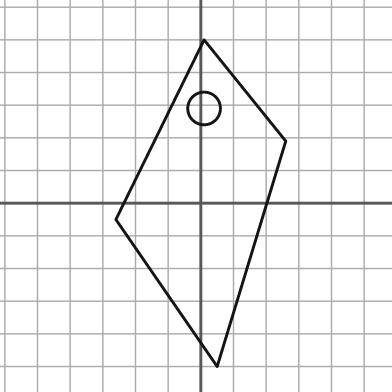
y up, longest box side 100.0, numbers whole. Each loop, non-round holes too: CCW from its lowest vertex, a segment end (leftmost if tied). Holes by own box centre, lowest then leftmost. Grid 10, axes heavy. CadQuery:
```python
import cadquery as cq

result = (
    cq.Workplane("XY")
    .moveTo(5.0, -50.0)
    .lineTo(26.0, 19.0)
    .lineTo(1.0, 50.0)
    .lineTo(-26.0, -5.0)
    .close()
    .moveTo(1.0, 29.0)
    .circle(5.0)
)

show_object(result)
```